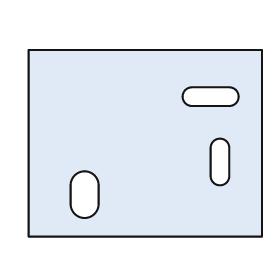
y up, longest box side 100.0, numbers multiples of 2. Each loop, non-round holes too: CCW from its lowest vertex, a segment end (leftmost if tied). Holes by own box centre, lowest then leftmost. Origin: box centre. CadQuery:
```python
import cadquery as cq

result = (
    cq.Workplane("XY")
    .moveTo(-50.0, -40.0)
    .lineTo(50.0, -40.0)
    .lineTo(50.0, 40.0)
    .lineTo(-50.0, 40.0)
    .close()
    .moveTo(-32.0, -26.0)
    .threePointArc((-26.0, -32.0), (-20.0, -26.0))
    .lineTo(-20.0, -18.0)
    .threePointArc((-26.0, -12.0), (-32.0, -18.0))
    .close()
    .moveTo(28.0, -14.0)
    .threePointArc((32.0, -18.0), (36.0, -14.0))
    .lineTo(36.0, -2.0)
    .threePointArc((32.0, 2.0), (28.0, -2.0))
    .close()
    .moveTo(20.0, 16.0)
    .lineTo(36.0, 16.0)
    .threePointArc((40.0, 20.0), (36.0, 24.0))
    .lineTo(20.0, 24.0)
    .threePointArc((16.0, 20.0), (20.0, 16.0))
    .close()
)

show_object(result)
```